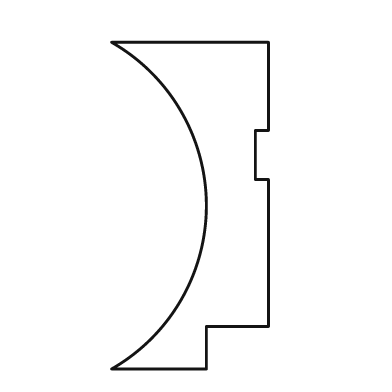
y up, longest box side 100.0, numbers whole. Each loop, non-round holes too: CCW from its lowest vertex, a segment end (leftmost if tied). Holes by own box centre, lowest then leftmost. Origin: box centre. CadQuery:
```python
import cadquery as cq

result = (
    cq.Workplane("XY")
    .moveTo(-24.0, -50.0)
    .lineTo(5.0, -50.0)
    .lineTo(5.0, -37.0)
    .lineTo(24.0, -37.0)
    .lineTo(24.0, 8.0)
    .lineTo(20.0, 8.0)
    .lineTo(20.0, 23.0)
    .lineTo(24.0, 23.0)
    .lineTo(24.0, 50.0)
    .lineTo(-24.0, 50.0)
    .threePointArc((5.0, 0.0), (-24.0, -50.0))
    .close()
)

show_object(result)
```